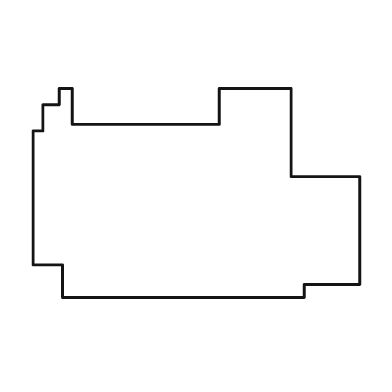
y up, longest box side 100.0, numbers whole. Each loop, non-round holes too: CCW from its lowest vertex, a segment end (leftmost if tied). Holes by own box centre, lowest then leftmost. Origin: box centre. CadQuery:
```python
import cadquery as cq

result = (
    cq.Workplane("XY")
    .moveTo(-41.0, -32.0)
    .lineTo(33.0, -32.0)
    .lineTo(33.0, -28.0)
    .lineTo(50.0, -28.0)
    .lineTo(50.0, 5.0)
    .lineTo(29.0, 5.0)
    .lineTo(29.0, 32.0)
    .lineTo(7.0, 32.0)
    .lineTo(7.0, 21.0)
    .lineTo(-38.0, 21.0)
    .lineTo(-38.0, 32.0)
    .lineTo(-42.0, 32.0)
    .lineTo(-42.0, 27.0)
    .lineTo(-47.0, 27.0)
    .lineTo(-47.0, 19.0)
    .lineTo(-50.0, 19.0)
    .lineTo(-50.0, -22.0)
    .lineTo(-41.0, -22.0)
    .close()
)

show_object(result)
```